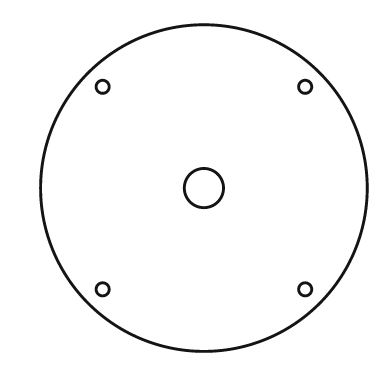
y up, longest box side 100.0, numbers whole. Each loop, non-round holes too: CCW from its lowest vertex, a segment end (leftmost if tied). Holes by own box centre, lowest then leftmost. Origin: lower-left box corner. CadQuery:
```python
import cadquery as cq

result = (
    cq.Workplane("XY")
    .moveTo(50.0, 50.0)
    .circle(50.0)
    .moveTo(19.0, 19.0)
    .circle(2.0)
    .moveTo(81.0, 19.0)
    .circle(2.0)
    .moveTo(50.0, 50.0)
    .circle(6.0)
    .moveTo(19.0, 81.0)
    .circle(2.0)
    .moveTo(81.0, 81.0)
    .circle(2.0)
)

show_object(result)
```